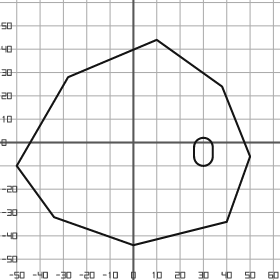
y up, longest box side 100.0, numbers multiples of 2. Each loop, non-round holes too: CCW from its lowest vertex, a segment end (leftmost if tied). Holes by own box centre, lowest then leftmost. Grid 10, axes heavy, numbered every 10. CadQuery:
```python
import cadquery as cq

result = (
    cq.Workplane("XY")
    .moveTo(0.0, -44.0)
    .lineTo(40.0, -34.0)
    .lineTo(50.0, -6.0)
    .lineTo(38.0, 24.0)
    .lineTo(10.0, 44.0)
    .lineTo(-28.0, 28.0)
    .lineTo(-50.0, -10.0)
    .lineTo(-34.0, -32.0)
    .close()
    .moveTo(26.0, -6.0)
    .threePointArc((30.0, -10.0), (34.0, -6.0))
    .lineTo(34.0, -2.0)
    .threePointArc((30.0, 2.0), (26.0, -2.0))
    .close()
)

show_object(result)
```